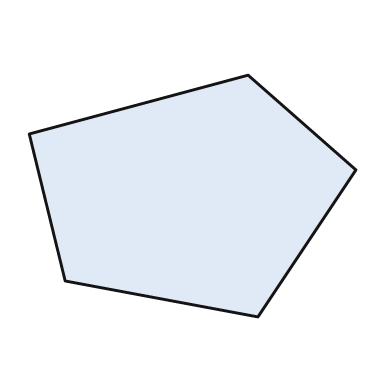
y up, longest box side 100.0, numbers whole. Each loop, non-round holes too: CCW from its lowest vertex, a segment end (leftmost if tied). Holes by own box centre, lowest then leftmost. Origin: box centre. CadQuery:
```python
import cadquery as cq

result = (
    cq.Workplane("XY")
    .moveTo(20.0, -37.0)
    .lineTo(50.0, 8.0)
    .lineTo(17.0, 37.0)
    .lineTo(-50.0, 19.0)
    .lineTo(-39.0, -26.0)
    .close()
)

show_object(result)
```